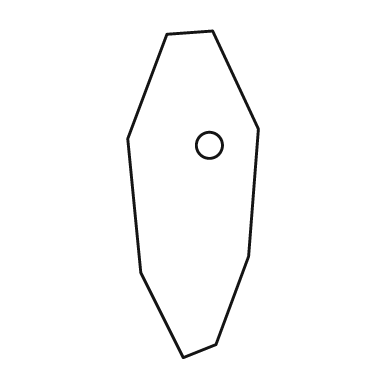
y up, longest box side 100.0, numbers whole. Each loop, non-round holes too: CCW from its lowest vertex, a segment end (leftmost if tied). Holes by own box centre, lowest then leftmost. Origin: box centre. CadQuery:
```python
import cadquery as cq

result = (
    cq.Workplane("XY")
    .moveTo(-3.0, -50.0)
    .lineTo(7.0, -46.0)
    .lineTo(17.0, -19.0)
    .lineTo(20.0, 20.0)
    .lineTo(6.0, 50.0)
    .lineTo(-8.0, 49.0)
    .lineTo(-20.0, 17.0)
    .lineTo(-16.0, -24.0)
    .close()
    .moveTo(5.0, 15.0)
    .circle(4.0)
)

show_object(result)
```